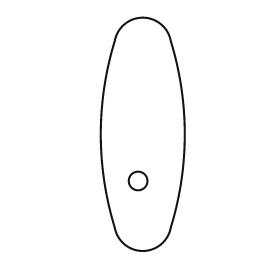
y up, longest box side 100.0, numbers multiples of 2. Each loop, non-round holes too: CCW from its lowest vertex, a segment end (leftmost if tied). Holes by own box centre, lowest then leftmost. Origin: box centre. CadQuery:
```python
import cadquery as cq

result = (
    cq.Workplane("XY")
    .moveTo(-12.0, -40.0)
    .threePointArc((0.0, -50.0), (12.0, -40.0))
    .threePointArc((18.0, 0.0), (12.0, 40.0))
    .threePointArc((0.0, 50.0), (-12.0, 40.0))
    .threePointArc((-18.0, 0.0), (-12.0, -40.0))
    .close()
    .moveTo(-2.0, -20.0)
    .circle(4.0)
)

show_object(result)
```